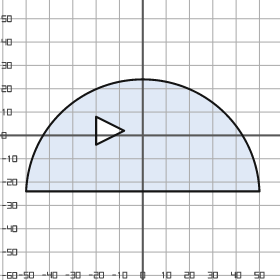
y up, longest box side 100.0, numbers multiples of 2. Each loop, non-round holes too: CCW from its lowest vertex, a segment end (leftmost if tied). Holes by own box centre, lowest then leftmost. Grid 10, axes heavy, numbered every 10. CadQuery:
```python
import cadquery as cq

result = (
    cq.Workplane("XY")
    .moveTo(-50.0, -24.0)
    .lineTo(50.0, -24.0)
    .threePointArc((0.0, 24.0), (-50.0, -24.0))
    .close()
    .moveTo(-20.0, -4.0)
    .lineTo(-8.0, 2.0)
    .lineTo(-20.0, 8.0)
    .close()
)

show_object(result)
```